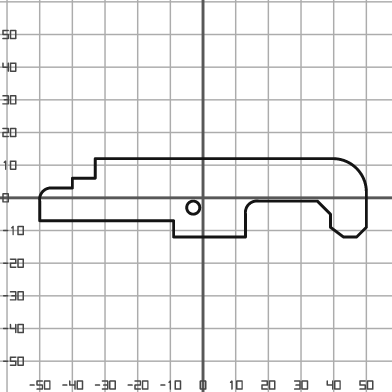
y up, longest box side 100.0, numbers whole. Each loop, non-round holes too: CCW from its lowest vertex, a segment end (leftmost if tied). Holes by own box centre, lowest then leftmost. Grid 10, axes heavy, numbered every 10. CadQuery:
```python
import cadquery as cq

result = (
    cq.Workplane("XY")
    .moveTo(-9.0, -12.0)
    .lineTo(13.0, -12.0)
    .lineTo(13.0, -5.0)
    .threePointArc((14.0, -2.0), (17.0, -1.0))
    .lineTo(35.0, -1.0)
    .lineTo(39.0, -5.0)
    .lineTo(39.0, -9.0)
    .lineTo(43.0, -12.0)
    .lineTo(47.0, -12.0)
    .lineTo(50.0, -9.0)
    .lineTo(50.0, 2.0)
    .threePointArc((47.0, 9.0), (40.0, 12.0))
    .lineTo(-33.0, 12.0)
    .lineTo(-33.0, 6.0)
    .lineTo(-40.0, 6.0)
    .lineTo(-40.0, 3.0)
    .lineTo(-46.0, 3.0)
    .threePointArc((-49.0, 2.0), (-50.0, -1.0))
    .lineTo(-50.0, -7.0)
    .lineTo(-9.0, -7.0)
    .close()
    .moveTo(-3.0, -3.0)
    .circle(2.0)
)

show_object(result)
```